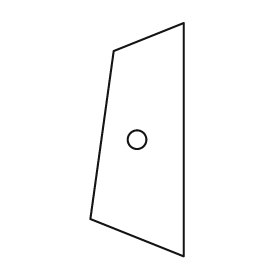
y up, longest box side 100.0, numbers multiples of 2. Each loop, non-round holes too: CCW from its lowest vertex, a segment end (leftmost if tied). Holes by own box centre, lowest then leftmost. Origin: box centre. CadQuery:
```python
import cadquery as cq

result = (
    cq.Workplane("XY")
    .moveTo(20.0, -50.0)
    .lineTo(20.0, 50.0)
    .lineTo(-10.0, 38.0)
    .lineTo(-20.0, -34.0)
    .close()
    .moveTo(0.0, 0.0)
    .circle(4.0)
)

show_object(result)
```